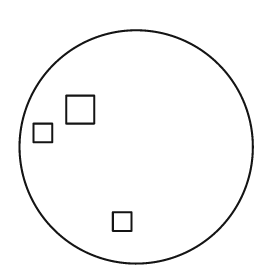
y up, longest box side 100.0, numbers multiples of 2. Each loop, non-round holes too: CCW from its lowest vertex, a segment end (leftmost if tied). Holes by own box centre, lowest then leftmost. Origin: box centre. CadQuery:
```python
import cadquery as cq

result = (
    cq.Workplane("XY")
    .moveTo(0.0, 0.0)
    .circle(50.0)
    .moveTo(-10.0, -36.0)
    .lineTo(-2.0, -36.0)
    .lineTo(-2.0, -28.0)
    .lineTo(-10.0, -28.0)
    .close()
    .moveTo(-44.0, 2.0)
    .lineTo(-36.0, 2.0)
    .lineTo(-36.0, 10.0)
    .lineTo(-44.0, 10.0)
    .close()
    .moveTo(-30.0, 10.0)
    .lineTo(-18.0, 10.0)
    .lineTo(-18.0, 22.0)
    .lineTo(-30.0, 22.0)
    .close()
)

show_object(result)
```